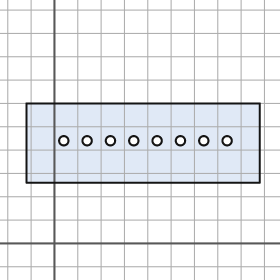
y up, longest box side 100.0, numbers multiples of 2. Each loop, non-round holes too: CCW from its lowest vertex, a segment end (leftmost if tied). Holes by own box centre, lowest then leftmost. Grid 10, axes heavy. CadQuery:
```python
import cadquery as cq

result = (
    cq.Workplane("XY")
    .moveTo(-12.0, 26.0)
    .lineTo(88.0, 26.0)
    .lineTo(88.0, 60.0)
    .lineTo(-12.0, 60.0)
    .close()
    .moveTo(4.0, 44.0)
    .circle(2.0)
    .moveTo(14.0, 44.0)
    .circle(2.0)
    .moveTo(24.0, 44.0)
    .circle(2.0)
    .moveTo(34.0, 44.0)
    .circle(2.0)
    .moveTo(44.0, 44.0)
    .circle(2.0)
    .moveTo(54.0, 44.0)
    .circle(2.0)
    .moveTo(64.0, 44.0)
    .circle(2.0)
    .moveTo(74.0, 44.0)
    .circle(2.0)
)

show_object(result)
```